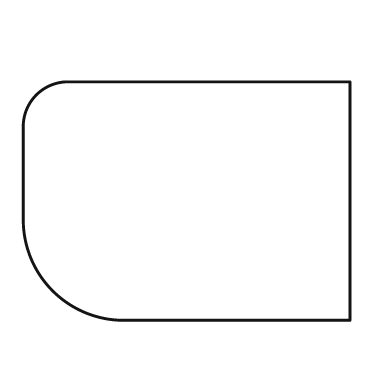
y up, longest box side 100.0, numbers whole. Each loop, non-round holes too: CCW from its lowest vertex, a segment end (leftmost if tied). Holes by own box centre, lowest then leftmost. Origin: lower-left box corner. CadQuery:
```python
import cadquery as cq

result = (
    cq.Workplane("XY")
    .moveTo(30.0, 0.0)
    .lineTo(100.0, 0.0)
    .lineTo(100.0, 73.0)
    .lineTo(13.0, 73.0)
    .threePointArc((4.0, 69.0), (0.0, 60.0))
    .lineTo(0.0, 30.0)
    .threePointArc((9.0, 9.0), (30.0, 0.0))
    .close()
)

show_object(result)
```